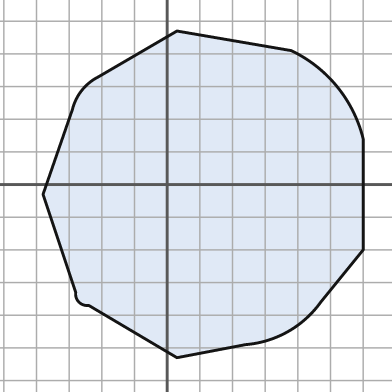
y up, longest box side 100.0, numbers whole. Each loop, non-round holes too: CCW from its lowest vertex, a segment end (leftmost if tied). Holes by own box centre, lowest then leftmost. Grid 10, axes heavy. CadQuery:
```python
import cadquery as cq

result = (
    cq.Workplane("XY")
    .moveTo(3.0, -53.0)
    .lineTo(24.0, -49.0)
    .threePointArc((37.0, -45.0), (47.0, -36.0))
    .lineTo(60.0, -20.0)
    .lineTo(60.0, 14.0)
    .threePointArc((52.0, 30.0), (38.0, 41.0))
    .lineTo(3.0, 47.0)
    .lineTo(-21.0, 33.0)
    .threePointArc((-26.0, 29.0), (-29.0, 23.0))
    .lineTo(-38.0, -3.0)
    .lineTo(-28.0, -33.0)
    .threePointArc((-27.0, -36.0), (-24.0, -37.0))
    .close()
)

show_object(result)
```